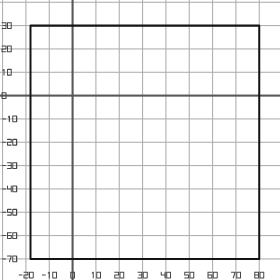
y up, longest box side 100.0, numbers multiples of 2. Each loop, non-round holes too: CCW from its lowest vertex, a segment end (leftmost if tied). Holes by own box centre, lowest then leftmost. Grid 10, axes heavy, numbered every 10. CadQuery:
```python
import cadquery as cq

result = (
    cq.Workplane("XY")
    .moveTo(-18.0, -70.0)
    .lineTo(80.0, -70.0)
    .lineTo(80.0, 30.0)
    .lineTo(-18.0, 30.0)
    .close()
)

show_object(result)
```